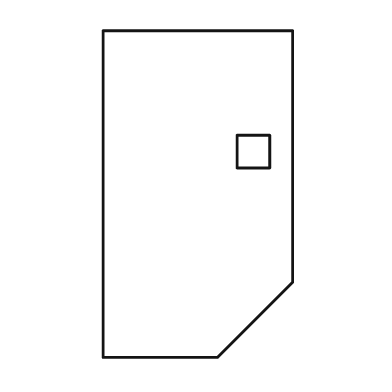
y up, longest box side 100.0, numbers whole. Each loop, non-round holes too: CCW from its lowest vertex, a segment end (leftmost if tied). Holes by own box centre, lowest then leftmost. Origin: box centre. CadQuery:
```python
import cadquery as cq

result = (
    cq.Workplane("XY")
    .moveTo(-29.0, -50.0)
    .lineTo(6.0, -50.0)
    .lineTo(29.0, -27.0)
    .lineTo(29.0, 50.0)
    .lineTo(-29.0, 50.0)
    .close()
    .moveTo(12.0, 8.0)
    .lineTo(22.0, 8.0)
    .lineTo(22.0, 18.0)
    .lineTo(12.0, 18.0)
    .close()
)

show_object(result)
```